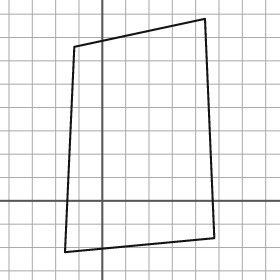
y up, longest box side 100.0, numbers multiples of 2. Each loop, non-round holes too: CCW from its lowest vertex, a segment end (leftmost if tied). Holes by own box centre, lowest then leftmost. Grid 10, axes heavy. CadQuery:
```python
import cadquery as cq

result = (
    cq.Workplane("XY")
    .moveTo(-16.0, -22.0)
    .lineTo(48.0, -16.0)
    .lineTo(44.0, 78.0)
    .lineTo(-12.0, 66.0)
    .close()
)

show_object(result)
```